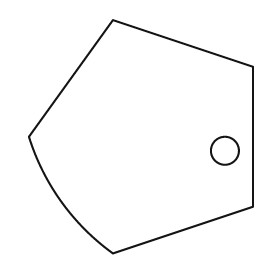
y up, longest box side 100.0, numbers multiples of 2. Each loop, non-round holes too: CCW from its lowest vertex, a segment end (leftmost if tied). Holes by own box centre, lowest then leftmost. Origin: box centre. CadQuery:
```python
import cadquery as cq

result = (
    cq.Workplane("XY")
    .moveTo(-12.0, -50.0)
    .lineTo(48.0, -30.0)
    .lineTo(48.0, 30.0)
    .lineTo(-12.0, 50.0)
    .lineTo(-48.0, 0.0)
    .threePointArc((-34.0, -28.0), (-12.0, -50.0))
    .close()
    .moveTo(36.0, -6.0)
    .circle(6.0)
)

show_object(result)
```